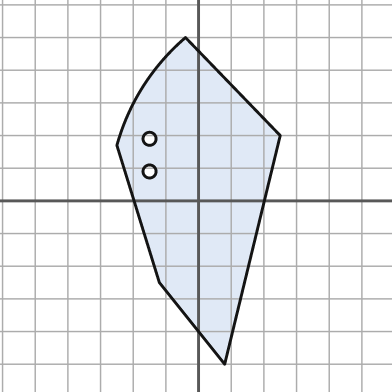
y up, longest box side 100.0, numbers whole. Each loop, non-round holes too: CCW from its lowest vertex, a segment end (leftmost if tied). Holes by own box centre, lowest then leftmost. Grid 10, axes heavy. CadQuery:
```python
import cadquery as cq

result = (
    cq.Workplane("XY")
    .moveTo(8.0, -50.0)
    .lineTo(25.0, 20.0)
    .lineTo(-4.0, 50.0)
    .threePointArc((-17.0, 35.0), (-25.0, 17.0))
    .lineTo(-12.0, -25.0)
    .close()
    .moveTo(-15.0, 9.0)
    .circle(2.0)
    .moveTo(-15.0, 19.0)
    .circle(2.0)
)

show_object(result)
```